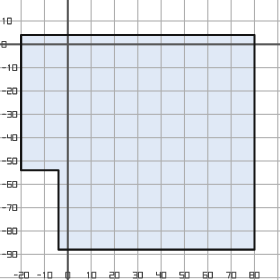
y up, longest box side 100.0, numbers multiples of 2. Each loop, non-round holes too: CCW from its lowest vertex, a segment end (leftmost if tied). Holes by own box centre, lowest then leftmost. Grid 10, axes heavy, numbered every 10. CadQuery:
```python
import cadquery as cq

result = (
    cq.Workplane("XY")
    .moveTo(-4.0, -88.0)
    .lineTo(80.0, -88.0)
    .lineTo(80.0, 4.0)
    .lineTo(-20.0, 4.0)
    .lineTo(-20.0, -54.0)
    .lineTo(-4.0, -54.0)
    .close()
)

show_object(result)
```